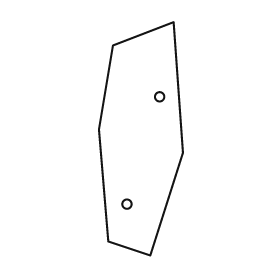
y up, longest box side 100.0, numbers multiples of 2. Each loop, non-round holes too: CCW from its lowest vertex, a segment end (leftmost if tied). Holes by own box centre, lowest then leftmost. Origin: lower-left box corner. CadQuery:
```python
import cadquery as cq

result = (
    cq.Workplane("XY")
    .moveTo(22.0, 0.0)
    .lineTo(36.0, 44.0)
    .lineTo(32.0, 100.0)
    .lineTo(6.0, 90.0)
    .lineTo(0.0, 54.0)
    .lineTo(4.0, 6.0)
    .close()
    .moveTo(12.0, 22.0)
    .circle(2.0)
    .moveTo(26.0, 68.0)
    .circle(2.0)
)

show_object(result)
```